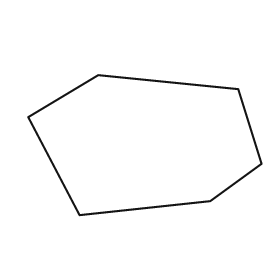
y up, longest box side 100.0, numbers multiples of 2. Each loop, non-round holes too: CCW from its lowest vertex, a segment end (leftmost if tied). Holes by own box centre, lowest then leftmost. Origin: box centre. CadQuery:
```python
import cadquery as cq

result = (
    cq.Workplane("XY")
    .moveTo(-28.0, -30.0)
    .lineTo(28.0, -24.0)
    .lineTo(50.0, -8.0)
    .lineTo(40.0, 24.0)
    .lineTo(-20.0, 30.0)
    .lineTo(-50.0, 12.0)
    .close()
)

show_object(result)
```